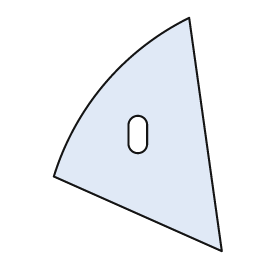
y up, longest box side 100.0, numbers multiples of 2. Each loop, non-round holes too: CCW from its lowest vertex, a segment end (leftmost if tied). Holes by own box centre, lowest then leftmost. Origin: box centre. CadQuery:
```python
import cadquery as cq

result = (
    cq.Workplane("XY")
    .moveTo(36.0, -50.0)
    .lineTo(22.0, 50.0)
    .threePointArc((-14.0, 22.0), (-36.0, -18.0))
    .close()
    .moveTo(-4.0, -4.0)
    .threePointArc((0.0, -8.0), (4.0, -4.0))
    .lineTo(4.0, 4.0)
    .threePointArc((0.0, 8.0), (-4.0, 4.0))
    .close()
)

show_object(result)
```